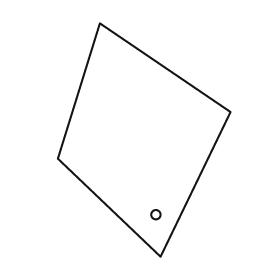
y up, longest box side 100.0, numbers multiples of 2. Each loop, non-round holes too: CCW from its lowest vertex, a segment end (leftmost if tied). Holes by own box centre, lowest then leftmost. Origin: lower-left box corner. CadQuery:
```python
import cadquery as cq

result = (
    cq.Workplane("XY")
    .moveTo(44.0, 0.0)
    .lineTo(74.0, 62.0)
    .lineTo(18.0, 100.0)
    .lineTo(0.0, 42.0)
    .close()
    .moveTo(42.0, 18.0)
    .circle(2.0)
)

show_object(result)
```